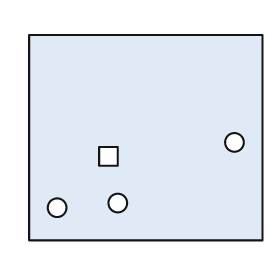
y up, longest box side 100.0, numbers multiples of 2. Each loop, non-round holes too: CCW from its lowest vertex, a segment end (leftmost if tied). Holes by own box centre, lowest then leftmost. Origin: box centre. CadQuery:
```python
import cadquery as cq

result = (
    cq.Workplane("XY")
    .moveTo(-50.0, -44.0)
    .lineTo(50.0, -44.0)
    .lineTo(50.0, 44.0)
    .lineTo(-50.0, 44.0)
    .close()
    .moveTo(-38.0, -30.0)
    .circle(4.0)
    .moveTo(-12.0, -28.0)
    .circle(4.0)
    .moveTo(-20.0, -12.0)
    .lineTo(-12.0, -12.0)
    .lineTo(-12.0, -4.0)
    .lineTo(-20.0, -4.0)
    .close()
    .moveTo(38.0, -2.0)
    .circle(4.0)
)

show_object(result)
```